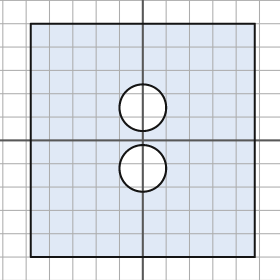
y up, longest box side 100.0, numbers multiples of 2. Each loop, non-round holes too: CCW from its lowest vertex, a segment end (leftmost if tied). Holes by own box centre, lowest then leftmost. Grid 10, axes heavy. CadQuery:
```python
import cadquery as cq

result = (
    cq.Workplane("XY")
    .moveTo(-48.0, -50.0)
    .lineTo(48.0, -50.0)
    .lineTo(48.0, 50.0)
    .lineTo(-48.0, 50.0)
    .close()
    .moveTo(0.0, -12.0)
    .circle(10.0)
    .moveTo(0.0, 14.0)
    .circle(10.0)
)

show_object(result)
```